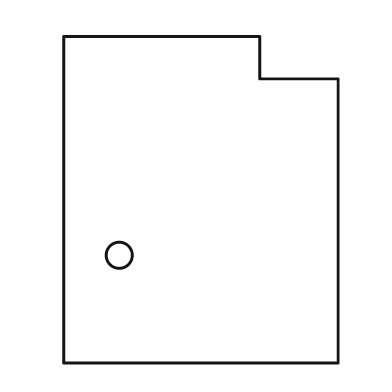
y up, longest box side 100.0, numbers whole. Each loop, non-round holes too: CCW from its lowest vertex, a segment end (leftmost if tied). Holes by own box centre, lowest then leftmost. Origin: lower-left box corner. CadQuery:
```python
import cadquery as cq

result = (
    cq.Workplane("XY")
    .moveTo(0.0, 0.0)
    .lineTo(84.0, 0.0)
    .lineTo(84.0, 87.0)
    .lineTo(60.0, 87.0)
    .lineTo(60.0, 100.0)
    .lineTo(0.0, 100.0)
    .close()
    .moveTo(17.0, 33.0)
    .circle(4.0)
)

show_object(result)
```